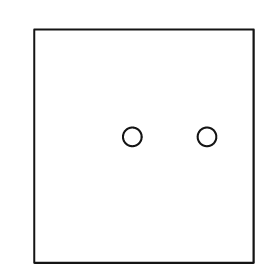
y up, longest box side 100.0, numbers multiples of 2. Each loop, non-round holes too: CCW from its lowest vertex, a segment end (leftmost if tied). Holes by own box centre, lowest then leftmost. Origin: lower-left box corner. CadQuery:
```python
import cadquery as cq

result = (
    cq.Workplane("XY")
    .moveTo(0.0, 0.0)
    .lineTo(94.0, 0.0)
    .lineTo(94.0, 100.0)
    .lineTo(0.0, 100.0)
    .close()
    .moveTo(42.0, 54.0)
    .circle(4.0)
    .moveTo(74.0, 54.0)
    .circle(4.0)
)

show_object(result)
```